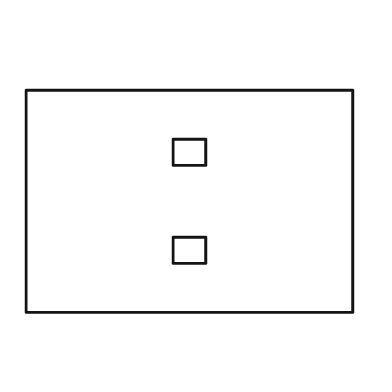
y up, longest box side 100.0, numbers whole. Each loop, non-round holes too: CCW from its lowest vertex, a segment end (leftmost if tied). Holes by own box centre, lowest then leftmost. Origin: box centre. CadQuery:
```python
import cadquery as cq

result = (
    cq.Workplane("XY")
    .moveTo(-50.0, -34.0)
    .lineTo(50.0, -34.0)
    .lineTo(50.0, 34.0)
    .lineTo(-50.0, 34.0)
    .close()
    .moveTo(-5.0, -19.0)
    .lineTo(5.0, -19.0)
    .lineTo(5.0, -11.0)
    .lineTo(-5.0, -11.0)
    .close()
    .moveTo(-5.0, 11.0)
    .lineTo(5.0, 11.0)
    .lineTo(5.0, 19.0)
    .lineTo(-5.0, 19.0)
    .close()
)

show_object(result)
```